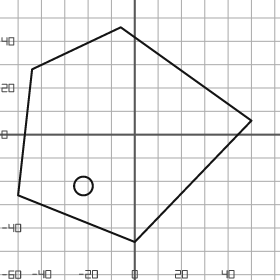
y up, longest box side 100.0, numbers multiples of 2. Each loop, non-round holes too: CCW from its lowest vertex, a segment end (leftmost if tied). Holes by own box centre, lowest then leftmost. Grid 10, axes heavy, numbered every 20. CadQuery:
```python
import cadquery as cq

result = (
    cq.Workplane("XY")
    .moveTo(0.0, -46.0)
    .lineTo(50.0, 6.0)
    .lineTo(-6.0, 46.0)
    .lineTo(-44.0, 28.0)
    .lineTo(-50.0, -26.0)
    .close()
    .moveTo(-22.0, -22.0)
    .circle(4.0)
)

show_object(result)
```